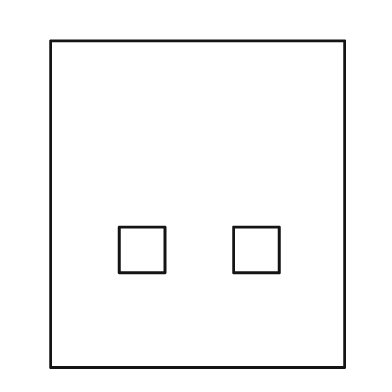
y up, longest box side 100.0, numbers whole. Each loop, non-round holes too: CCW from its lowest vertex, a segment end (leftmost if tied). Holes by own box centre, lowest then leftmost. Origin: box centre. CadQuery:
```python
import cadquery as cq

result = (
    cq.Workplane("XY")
    .moveTo(-45.0, -50.0)
    .lineTo(45.0, -50.0)
    .lineTo(45.0, 50.0)
    .lineTo(-45.0, 50.0)
    .close()
    .moveTo(-24.0, -21.0)
    .lineTo(-10.0, -21.0)
    .lineTo(-10.0, -7.0)
    .lineTo(-24.0, -7.0)
    .close()
    .moveTo(11.0, -21.0)
    .lineTo(25.0, -21.0)
    .lineTo(25.0, -7.0)
    .lineTo(11.0, -7.0)
    .close()
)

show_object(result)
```